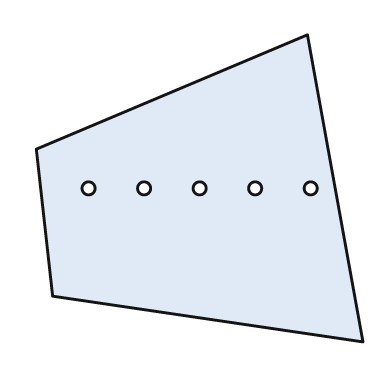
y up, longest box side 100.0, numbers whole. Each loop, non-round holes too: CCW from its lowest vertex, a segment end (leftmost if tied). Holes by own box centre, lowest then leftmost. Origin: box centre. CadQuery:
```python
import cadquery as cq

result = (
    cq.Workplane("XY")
    .moveTo(50.0, -47.0)
    .lineTo(33.0, 47.0)
    .lineTo(-50.0, 12.0)
    .lineTo(-45.0, -33.0)
    .close()
    .moveTo(-34.0, 0.0)
    .circle(2.0)
    .moveTo(-17.0, 0.0)
    .circle(2.0)
    .moveTo(0.0, 0.0)
    .circle(2.0)
    .moveTo(17.0, 0.0)
    .circle(2.0)
    .moveTo(34.0, 0.0)
    .circle(2.0)
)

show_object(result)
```